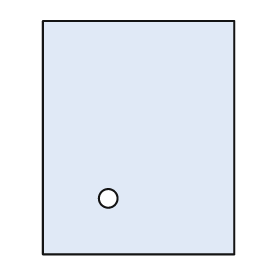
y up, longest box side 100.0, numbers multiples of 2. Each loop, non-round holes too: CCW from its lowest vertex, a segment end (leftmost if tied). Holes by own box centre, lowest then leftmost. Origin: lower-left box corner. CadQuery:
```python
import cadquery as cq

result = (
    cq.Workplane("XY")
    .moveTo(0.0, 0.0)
    .lineTo(82.0, 0.0)
    .lineTo(82.0, 100.0)
    .lineTo(0.0, 100.0)
    .close()
    .moveTo(28.0, 24.0)
    .circle(4.0)
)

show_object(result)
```